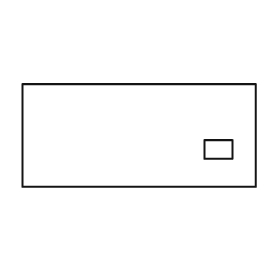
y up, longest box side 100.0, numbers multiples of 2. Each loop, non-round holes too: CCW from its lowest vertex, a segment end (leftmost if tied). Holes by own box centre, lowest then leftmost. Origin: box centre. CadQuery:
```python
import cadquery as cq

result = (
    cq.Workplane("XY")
    .moveTo(-50.0, -22.0)
    .lineTo(50.0, -22.0)
    .lineTo(50.0, 22.0)
    .lineTo(-50.0, 22.0)
    .close()
    .moveTo(28.0, -10.0)
    .lineTo(40.0, -10.0)
    .lineTo(40.0, -2.0)
    .lineTo(28.0, -2.0)
    .close()
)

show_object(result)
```